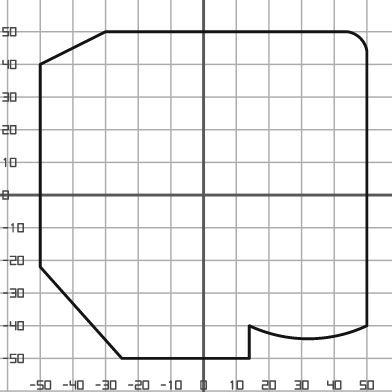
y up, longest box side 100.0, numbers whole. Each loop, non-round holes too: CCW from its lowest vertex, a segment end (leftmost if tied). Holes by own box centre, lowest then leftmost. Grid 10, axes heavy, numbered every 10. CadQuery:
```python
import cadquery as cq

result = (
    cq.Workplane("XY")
    .moveTo(-25.0, -50.0)
    .lineTo(14.0, -50.0)
    .lineTo(14.0, -40.0)
    .threePointArc((32.0, -44.0), (50.0, -40.0))
    .lineTo(50.0, 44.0)
    .threePointArc((48.0, 48.0), (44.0, 50.0))
    .lineTo(-30.0, 50.0)
    .lineTo(-50.0, 40.0)
    .lineTo(-50.0, -22.0)
    .close()
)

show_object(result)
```